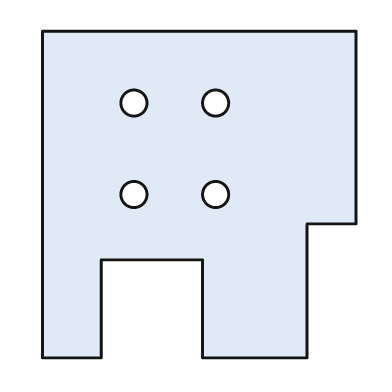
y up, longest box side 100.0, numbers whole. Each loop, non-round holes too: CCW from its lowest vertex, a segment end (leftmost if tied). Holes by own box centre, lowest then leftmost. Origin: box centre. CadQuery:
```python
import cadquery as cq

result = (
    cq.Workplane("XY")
    .moveTo(-48.0, -50.0)
    .lineTo(-30.0, -50.0)
    .lineTo(-30.0, -20.0)
    .lineTo(1.0, -20.0)
    .lineTo(1.0, -50.0)
    .lineTo(33.0, -50.0)
    .lineTo(33.0, -9.0)
    .lineTo(48.0, -9.0)
    .lineTo(48.0, 50.0)
    .lineTo(-48.0, 50.0)
    .close()
    .moveTo(-20.0, 0.0)
    .circle(4.0)
    .moveTo(5.0, 0.0)
    .circle(4.0)
    .moveTo(-20.0, 28.0)
    .circle(4.0)
    .moveTo(5.0, 28.0)
    .circle(4.0)
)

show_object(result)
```